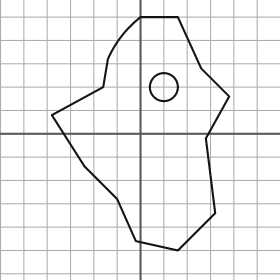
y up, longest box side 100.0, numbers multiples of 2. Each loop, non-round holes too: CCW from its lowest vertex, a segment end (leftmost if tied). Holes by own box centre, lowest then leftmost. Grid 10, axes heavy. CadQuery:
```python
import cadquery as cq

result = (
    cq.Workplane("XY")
    .moveTo(16.0, -50.0)
    .lineTo(32.0, -34.0)
    .lineTo(28.0, -2.0)
    .lineTo(38.0, 16.0)
    .lineTo(26.0, 28.0)
    .lineTo(16.0, 50.0)
    .lineTo(0.0, 50.0)
    .threePointArc((-8.0, 42.0), (-14.0, 32.0))
    .lineTo(-16.0, 20.0)
    .lineTo(-38.0, 8.0)
    .lineTo(-24.0, -14.0)
    .lineTo(-10.0, -28.0)
    .lineTo(-2.0, -46.0)
    .close()
    .moveTo(10.0, 20.0)
    .circle(6.0)
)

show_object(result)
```